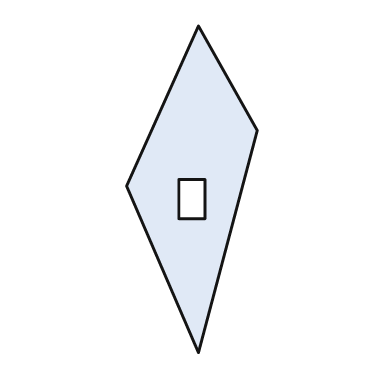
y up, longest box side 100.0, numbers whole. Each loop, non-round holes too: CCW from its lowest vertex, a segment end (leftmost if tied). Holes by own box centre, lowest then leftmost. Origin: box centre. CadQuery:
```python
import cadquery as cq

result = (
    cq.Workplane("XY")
    .moveTo(2.0, -50.0)
    .lineTo(20.0, 18.0)
    .lineTo(2.0, 50.0)
    .lineTo(-20.0, 1.0)
    .close()
    .moveTo(-4.0, -9.0)
    .lineTo(4.0, -9.0)
    .lineTo(4.0, 3.0)
    .lineTo(-4.0, 3.0)
    .close()
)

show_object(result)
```